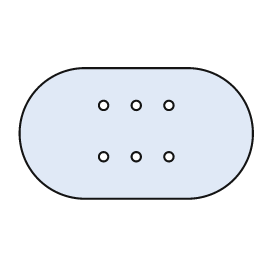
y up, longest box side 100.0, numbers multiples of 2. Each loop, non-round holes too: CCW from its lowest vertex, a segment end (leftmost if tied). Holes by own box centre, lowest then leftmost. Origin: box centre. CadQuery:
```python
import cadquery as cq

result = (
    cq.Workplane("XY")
    .moveTo(-22.0, -28.0)
    .lineTo(22.0, -28.0)
    .threePointArc((50.0, 0.0), (22.0, 28.0))
    .lineTo(-22.0, 28.0)
    .threePointArc((-50.0, 0.0), (-22.0, -28.0))
    .close()
    .moveTo(-14.0, -10.0)
    .circle(2.0)
    .moveTo(0.0, -10.0)
    .circle(2.0)
    .moveTo(14.0, -10.0)
    .circle(2.0)
    .moveTo(-14.0, 12.0)
    .circle(2.0)
    .moveTo(0.0, 12.0)
    .circle(2.0)
    .moveTo(14.0, 12.0)
    .circle(2.0)
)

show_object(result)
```